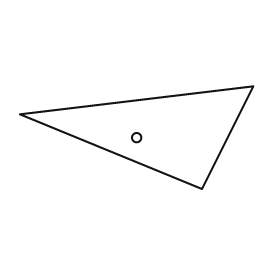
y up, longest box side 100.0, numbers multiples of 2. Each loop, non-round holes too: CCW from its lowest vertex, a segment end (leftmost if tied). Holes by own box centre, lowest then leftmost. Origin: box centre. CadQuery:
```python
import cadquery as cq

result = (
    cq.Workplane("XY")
    .moveTo(28.0, -22.0)
    .lineTo(50.0, 22.0)
    .lineTo(-50.0, 10.0)
    .close()
    .moveTo(0.0, 0.0)
    .circle(2.0)
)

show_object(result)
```